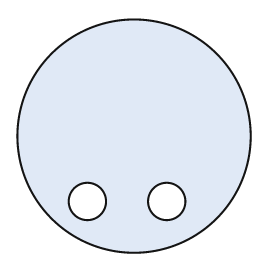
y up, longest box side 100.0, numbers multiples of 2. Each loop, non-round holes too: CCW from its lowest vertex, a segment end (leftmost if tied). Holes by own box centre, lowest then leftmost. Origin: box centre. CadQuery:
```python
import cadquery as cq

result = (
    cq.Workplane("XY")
    .moveTo(0.0, 0.0)
    .circle(50.0)
    .moveTo(-20.0, -28.0)
    .circle(8.0)
    .moveTo(14.0, -28.0)
    .circle(8.0)
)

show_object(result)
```